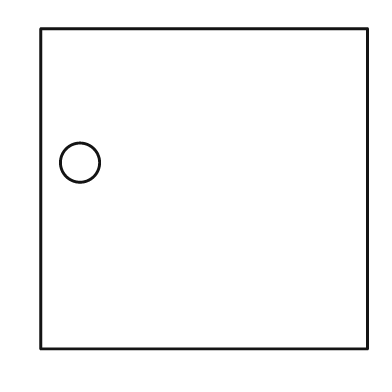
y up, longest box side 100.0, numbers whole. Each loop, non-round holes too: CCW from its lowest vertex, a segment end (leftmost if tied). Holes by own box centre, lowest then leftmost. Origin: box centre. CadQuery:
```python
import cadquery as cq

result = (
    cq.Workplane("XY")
    .moveTo(-50.0, -49.0)
    .lineTo(50.0, -49.0)
    .lineTo(50.0, 49.0)
    .lineTo(-50.0, 49.0)
    .close()
    .moveTo(-38.0, 8.0)
    .circle(6.0)
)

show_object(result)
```